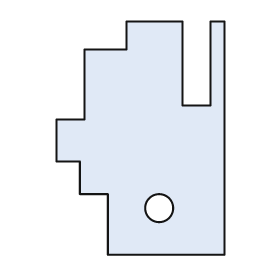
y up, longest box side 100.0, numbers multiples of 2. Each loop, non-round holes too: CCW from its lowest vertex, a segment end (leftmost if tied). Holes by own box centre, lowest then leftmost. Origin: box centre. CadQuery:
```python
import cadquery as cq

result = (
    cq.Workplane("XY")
    .moveTo(-14.0, -50.0)
    .lineTo(36.0, -50.0)
    .lineTo(36.0, 50.0)
    .lineTo(30.0, 50.0)
    .lineTo(30.0, 14.0)
    .lineTo(18.0, 14.0)
    .lineTo(18.0, 50.0)
    .lineTo(-6.0, 50.0)
    .lineTo(-6.0, 38.0)
    .lineTo(-24.0, 38.0)
    .lineTo(-24.0, 8.0)
    .lineTo(-36.0, 8.0)
    .lineTo(-36.0, -10.0)
    .lineTo(-26.0, -10.0)
    .lineTo(-26.0, -24.0)
    .lineTo(-14.0, -24.0)
    .close()
    .moveTo(8.0, -30.0)
    .circle(6.0)
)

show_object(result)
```